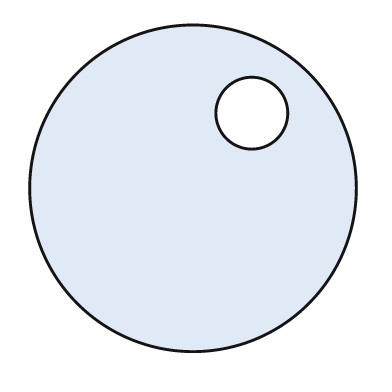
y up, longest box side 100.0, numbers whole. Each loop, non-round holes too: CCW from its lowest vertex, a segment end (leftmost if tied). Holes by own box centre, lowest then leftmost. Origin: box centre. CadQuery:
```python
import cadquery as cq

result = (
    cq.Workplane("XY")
    .moveTo(0.0, 0.0)
    .circle(50.0)
    .moveTo(18.0, 23.0)
    .circle(11.0)
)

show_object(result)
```